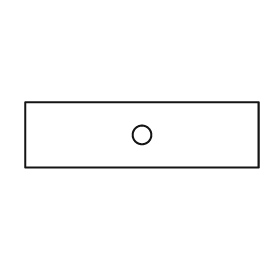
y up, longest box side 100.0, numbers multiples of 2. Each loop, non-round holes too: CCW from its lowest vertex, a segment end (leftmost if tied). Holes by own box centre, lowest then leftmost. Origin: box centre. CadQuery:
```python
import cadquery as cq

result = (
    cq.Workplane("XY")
    .moveTo(-50.0, -14.0)
    .lineTo(50.0, -14.0)
    .lineTo(50.0, 14.0)
    .lineTo(-50.0, 14.0)
    .close()
    .moveTo(0.0, 0.0)
    .circle(4.0)
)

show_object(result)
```